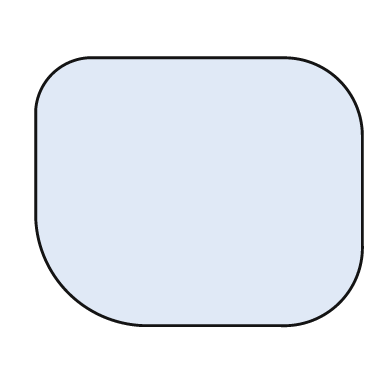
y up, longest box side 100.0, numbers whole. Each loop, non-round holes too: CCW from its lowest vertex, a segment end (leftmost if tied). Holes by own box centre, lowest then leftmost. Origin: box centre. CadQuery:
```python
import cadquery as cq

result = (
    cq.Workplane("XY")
    .moveTo(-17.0, -41.0)
    .lineTo(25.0, -41.0)
    .threePointArc((43.0, -34.0), (50.0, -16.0))
    .lineTo(50.0, 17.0)
    .threePointArc((43.0, 34.0), (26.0, 41.0))
    .lineTo(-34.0, 41.0)
    .threePointArc((-45.0, 36.0), (-50.0, 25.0))
    .lineTo(-50.0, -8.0)
    .threePointArc((-40.0, -31.0), (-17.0, -41.0))
    .close()
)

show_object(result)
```